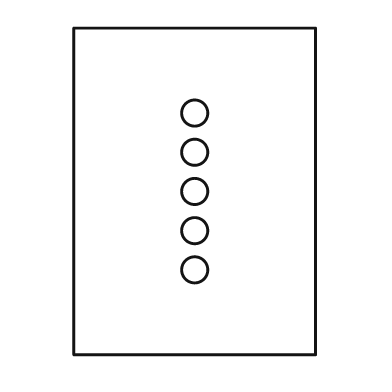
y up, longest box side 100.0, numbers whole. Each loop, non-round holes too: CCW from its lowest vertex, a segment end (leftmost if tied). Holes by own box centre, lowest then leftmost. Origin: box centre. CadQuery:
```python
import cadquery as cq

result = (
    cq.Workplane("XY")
    .moveTo(-37.0, -50.0)
    .lineTo(37.0, -50.0)
    .lineTo(37.0, 50.0)
    .lineTo(-37.0, 50.0)
    .close()
    .moveTo(0.0, -24.0)
    .circle(4.0)
    .moveTo(0.0, -12.0)
    .circle(4.0)
    .moveTo(0.0, 0.0)
    .circle(4.0)
    .moveTo(0.0, 12.0)
    .circle(4.0)
    .moveTo(0.0, 24.0)
    .circle(4.0)
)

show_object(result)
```